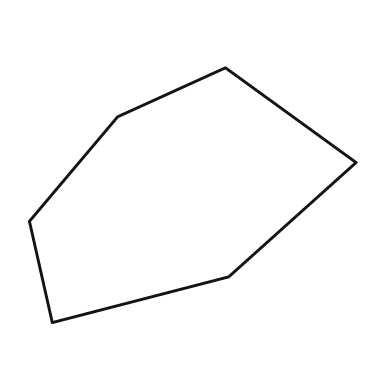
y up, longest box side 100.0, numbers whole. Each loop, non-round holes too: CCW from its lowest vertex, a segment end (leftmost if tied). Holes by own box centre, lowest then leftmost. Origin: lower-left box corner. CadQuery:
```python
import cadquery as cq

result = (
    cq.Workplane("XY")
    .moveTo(7.0, 0.0)
    .lineTo(61.0, 14.0)
    .lineTo(100.0, 49.0)
    .lineTo(60.0, 78.0)
    .lineTo(27.0, 63.0)
    .lineTo(0.0, 31.0)
    .close()
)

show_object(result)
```